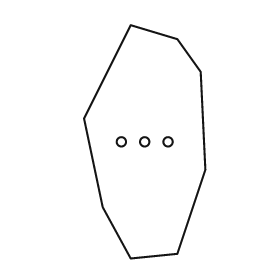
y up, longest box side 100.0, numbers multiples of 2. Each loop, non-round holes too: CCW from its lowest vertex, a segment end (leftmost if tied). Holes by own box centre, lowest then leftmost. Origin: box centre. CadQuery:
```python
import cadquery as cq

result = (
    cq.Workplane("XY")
    .moveTo(-6.0, -50.0)
    .lineTo(14.0, -48.0)
    .lineTo(26.0, -12.0)
    .lineTo(24.0, 30.0)
    .lineTo(14.0, 44.0)
    .lineTo(-6.0, 50.0)
    .lineTo(-26.0, 10.0)
    .lineTo(-18.0, -28.0)
    .close()
    .moveTo(-10.0, 0.0)
    .circle(2.0)
    .moveTo(0.0, 0.0)
    .circle(2.0)
    .moveTo(10.0, 0.0)
    .circle(2.0)
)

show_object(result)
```